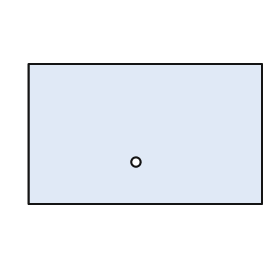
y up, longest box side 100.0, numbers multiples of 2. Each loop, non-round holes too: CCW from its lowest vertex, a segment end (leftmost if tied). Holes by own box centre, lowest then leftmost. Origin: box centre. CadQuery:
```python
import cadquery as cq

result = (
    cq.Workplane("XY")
    .moveTo(-50.0, -30.0)
    .lineTo(50.0, -30.0)
    .lineTo(50.0, 30.0)
    .lineTo(-50.0, 30.0)
    .close()
    .moveTo(-4.0, -12.0)
    .circle(2.0)
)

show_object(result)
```